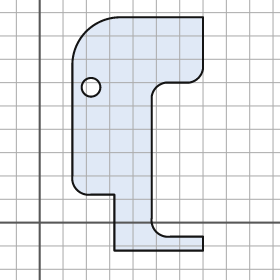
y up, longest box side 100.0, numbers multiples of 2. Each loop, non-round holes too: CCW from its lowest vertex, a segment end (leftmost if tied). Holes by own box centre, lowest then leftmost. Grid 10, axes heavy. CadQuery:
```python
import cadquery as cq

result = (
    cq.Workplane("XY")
    .moveTo(32.0, -12.0)
    .lineTo(70.0, -12.0)
    .lineTo(70.0, -6.0)
    .lineTo(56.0, -6.0)
    .threePointArc((50.0, -4.0), (48.0, 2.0))
    .lineTo(48.0, 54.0)
    .threePointArc((50.0, 58.0), (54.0, 60.0))
    .lineTo(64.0, 60.0)
    .threePointArc((68.0, 62.0), (70.0, 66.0))
    .lineTo(70.0, 88.0)
    .lineTo(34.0, 88.0)
    .threePointArc((20.0, 82.0), (14.0, 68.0))
    .lineTo(14.0, 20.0)
    .threePointArc((16.0, 14.0), (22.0, 12.0))
    .lineTo(32.0, 12.0)
    .close()
    .moveTo(22.0, 58.0)
    .circle(4.0)
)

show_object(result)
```